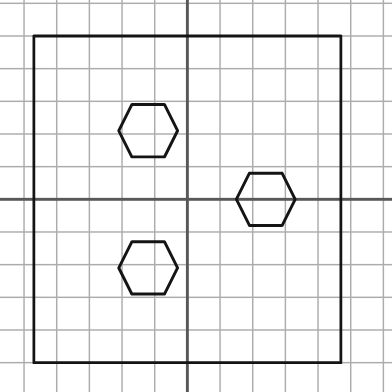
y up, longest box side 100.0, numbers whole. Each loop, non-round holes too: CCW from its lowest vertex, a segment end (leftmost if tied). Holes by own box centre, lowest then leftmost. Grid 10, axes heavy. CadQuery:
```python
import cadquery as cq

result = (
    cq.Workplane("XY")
    .moveTo(-47.0, -50.0)
    .lineTo(47.0, -50.0)
    .lineTo(47.0, 50.0)
    .lineTo(-47.0, 50.0)
    .close()
    .moveTo(-17.0, -29.0)
    .lineTo(-7.0, -29.0)
    .lineTo(-3.0, -21.0)
    .lineTo(-7.0, -13.0)
    .lineTo(-17.0, -13.0)
    .lineTo(-21.0, -21.0)
    .close()
    .moveTo(19.0, -8.0)
    .lineTo(29.0, -8.0)
    .lineTo(33.0, 0.0)
    .lineTo(29.0, 8.0)
    .lineTo(19.0, 8.0)
    .lineTo(15.0, 0.0)
    .close()
    .moveTo(-17.0, 13.0)
    .lineTo(-7.0, 13.0)
    .lineTo(-3.0, 21.0)
    .lineTo(-7.0, 29.0)
    .lineTo(-17.0, 29.0)
    .lineTo(-21.0, 21.0)
    .close()
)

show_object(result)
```